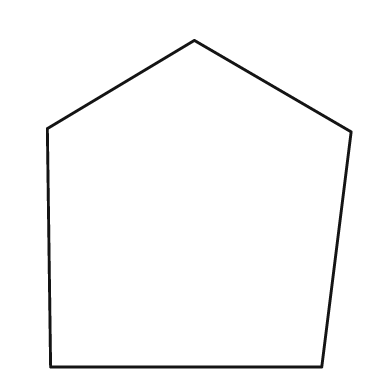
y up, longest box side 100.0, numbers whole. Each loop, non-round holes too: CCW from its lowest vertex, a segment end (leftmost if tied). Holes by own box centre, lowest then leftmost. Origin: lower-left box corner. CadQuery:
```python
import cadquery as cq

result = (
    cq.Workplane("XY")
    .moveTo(1.0, 0.0)
    .lineTo(84.0, 0.0)
    .lineTo(93.0, 72.0)
    .lineTo(45.0, 100.0)
    .lineTo(0.0, 73.0)
    .close()
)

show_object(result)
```